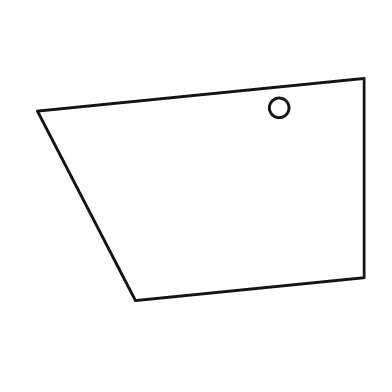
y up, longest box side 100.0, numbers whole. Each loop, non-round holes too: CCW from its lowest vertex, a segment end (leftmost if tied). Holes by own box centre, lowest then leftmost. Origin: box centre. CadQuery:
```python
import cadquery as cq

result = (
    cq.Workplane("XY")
    .moveTo(-20.0, -34.0)
    .lineTo(50.0, -27.0)
    .lineTo(50.0, 34.0)
    .lineTo(-50.0, 24.0)
    .close()
    .moveTo(24.0, 25.0)
    .circle(3.0)
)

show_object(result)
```